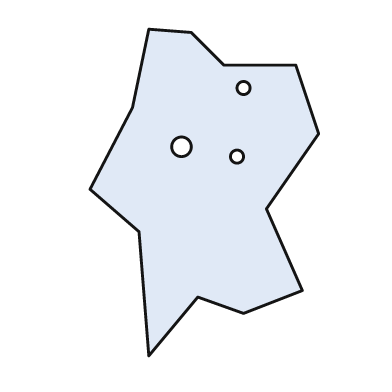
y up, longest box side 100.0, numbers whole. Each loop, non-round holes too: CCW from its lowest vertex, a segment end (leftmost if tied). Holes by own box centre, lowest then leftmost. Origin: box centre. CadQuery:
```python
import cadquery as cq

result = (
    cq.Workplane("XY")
    .moveTo(-17.0, -50.0)
    .lineTo(-2.0, -32.0)
    .lineTo(12.0, -37.0)
    .lineTo(30.0, -30.0)
    .lineTo(19.0, -5.0)
    .lineTo(35.0, 18.0)
    .lineTo(28.0, 39.0)
    .lineTo(6.0, 39.0)
    .lineTo(-4.0, 49.0)
    .lineTo(-17.0, 50.0)
    .lineTo(-22.0, 26.0)
    .lineTo(-35.0, 1.0)
    .lineTo(-20.0, -12.0)
    .close()
    .moveTo(10.0, 11.0)
    .circle(2.0)
    .moveTo(-7.0, 14.0)
    .circle(3.0)
    .moveTo(12.0, 32.0)
    .circle(2.0)
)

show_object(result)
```